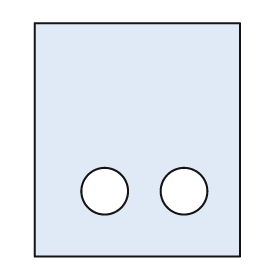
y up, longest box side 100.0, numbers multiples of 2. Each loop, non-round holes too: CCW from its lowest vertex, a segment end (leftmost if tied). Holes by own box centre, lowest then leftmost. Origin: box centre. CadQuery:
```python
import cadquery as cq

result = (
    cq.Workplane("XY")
    .moveTo(-44.0, -50.0)
    .lineTo(44.0, -50.0)
    .lineTo(44.0, 50.0)
    .lineTo(-44.0, 50.0)
    .close()
    .moveTo(-14.0, -22.0)
    .circle(10.0)
    .moveTo(20.0, -22.0)
    .circle(10.0)
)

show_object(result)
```